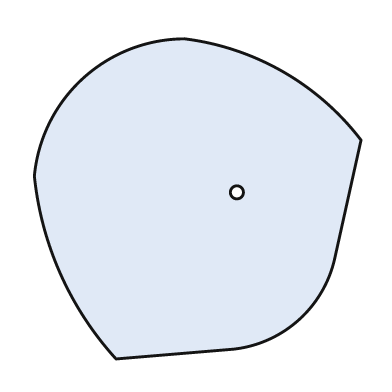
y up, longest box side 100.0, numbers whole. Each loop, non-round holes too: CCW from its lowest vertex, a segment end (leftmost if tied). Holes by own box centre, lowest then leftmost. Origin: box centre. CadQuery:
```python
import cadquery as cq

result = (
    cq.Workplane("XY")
    .moveTo(-25.0, -49.0)
    .lineTo(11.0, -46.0)
    .threePointArc((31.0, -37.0), (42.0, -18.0))
    .lineTo(50.0, 18.0)
    .threePointArc((26.0, 39.0), (-4.0, 49.0))
    .threePointArc((-35.0, 37.0), (-50.0, 7.0))
    .threePointArc((-42.0, -23.0), (-25.0, -49.0))
    .close()
    .moveTo(12.0, 2.0)
    .circle(2.0)
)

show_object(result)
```